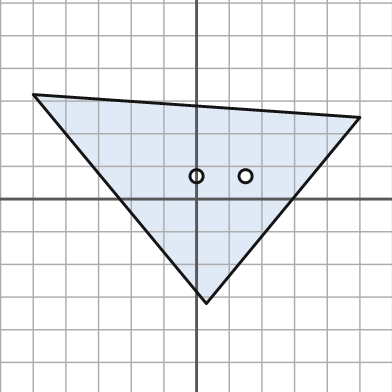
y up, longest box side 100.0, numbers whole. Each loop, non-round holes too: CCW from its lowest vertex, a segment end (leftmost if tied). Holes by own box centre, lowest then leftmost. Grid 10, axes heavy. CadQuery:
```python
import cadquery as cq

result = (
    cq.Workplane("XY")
    .moveTo(3.0, -32.0)
    .lineTo(50.0, 25.0)
    .lineTo(-50.0, 32.0)
    .close()
    .moveTo(0.0, 7.0)
    .circle(2.0)
    .moveTo(15.0, 7.0)
    .circle(2.0)
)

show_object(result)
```